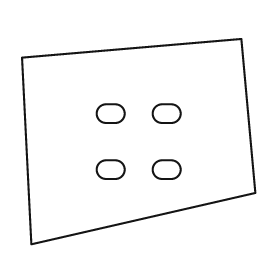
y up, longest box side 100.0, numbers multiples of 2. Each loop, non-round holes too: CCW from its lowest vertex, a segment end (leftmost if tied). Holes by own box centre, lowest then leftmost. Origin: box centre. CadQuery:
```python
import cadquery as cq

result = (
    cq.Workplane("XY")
    .moveTo(-46.0, -44.0)
    .lineTo(50.0, -22.0)
    .lineTo(44.0, 44.0)
    .lineTo(-50.0, 36.0)
    .close()
    .moveTo(-14.0, -16.0)
    .lineTo(-10.0, -16.0)
    .threePointArc((-6.0, -12.0), (-10.0, -8.0))
    .lineTo(-14.0, -8.0)
    .threePointArc((-18.0, -12.0), (-14.0, -16.0))
    .close()
    .moveTo(10.0, -16.0)
    .lineTo(14.0, -16.0)
    .threePointArc((18.0, -12.0), (14.0, -8.0))
    .lineTo(10.0, -8.0)
    .threePointArc((6.0, -12.0), (10.0, -16.0))
    .close()
    .moveTo(-14.0, 8.0)
    .lineTo(-10.0, 8.0)
    .threePointArc((-6.0, 12.0), (-10.0, 16.0))
    .lineTo(-14.0, 16.0)
    .threePointArc((-18.0, 12.0), (-14.0, 8.0))
    .close()
    .moveTo(10.0, 8.0)
    .lineTo(14.0, 8.0)
    .threePointArc((18.0, 12.0), (14.0, 16.0))
    .lineTo(10.0, 16.0)
    .threePointArc((6.0, 12.0), (10.0, 8.0))
    .close()
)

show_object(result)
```